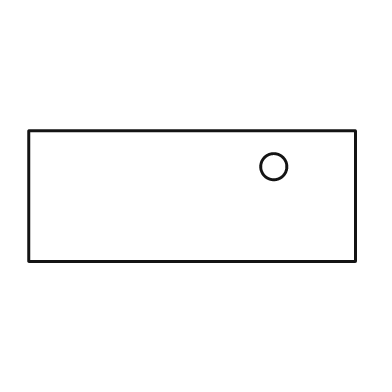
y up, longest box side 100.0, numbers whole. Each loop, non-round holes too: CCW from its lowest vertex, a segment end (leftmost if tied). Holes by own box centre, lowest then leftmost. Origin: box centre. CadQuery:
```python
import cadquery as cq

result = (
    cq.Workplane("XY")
    .moveTo(-50.0, -20.0)
    .lineTo(50.0, -20.0)
    .lineTo(50.0, 20.0)
    .lineTo(-50.0, 20.0)
    .close()
    .moveTo(25.0, 9.0)
    .circle(4.0)
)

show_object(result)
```